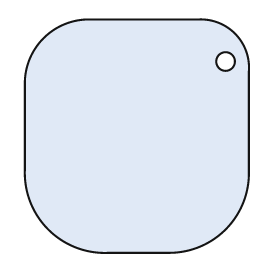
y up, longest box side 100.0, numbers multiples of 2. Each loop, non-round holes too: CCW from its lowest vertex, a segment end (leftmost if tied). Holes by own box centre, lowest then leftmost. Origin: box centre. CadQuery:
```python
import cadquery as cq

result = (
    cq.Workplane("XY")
    .moveTo(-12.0, -50.0)
    .lineTo(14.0, -50.0)
    .threePointArc((38.0, -40.0), (48.0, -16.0))
    .lineTo(48.0, 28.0)
    .threePointArc((42.0, 44.0), (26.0, 50.0))
    .lineTo(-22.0, 50.0)
    .threePointArc((-40.0, 42.0), (-48.0, 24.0))
    .lineTo(-48.0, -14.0)
    .threePointArc((-38.0, -40.0), (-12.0, -50.0))
    .close()
    .moveTo(38.0, 32.0)
    .circle(4.0)
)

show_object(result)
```